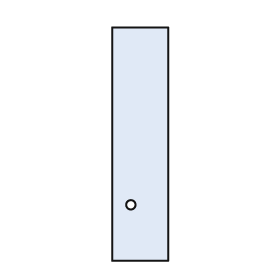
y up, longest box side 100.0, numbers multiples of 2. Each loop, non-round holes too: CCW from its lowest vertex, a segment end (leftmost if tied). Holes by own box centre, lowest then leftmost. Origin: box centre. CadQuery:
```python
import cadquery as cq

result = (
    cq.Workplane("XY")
    .moveTo(-12.0, -50.0)
    .lineTo(12.0, -50.0)
    .lineTo(12.0, 50.0)
    .lineTo(-12.0, 50.0)
    .close()
    .moveTo(-4.0, -26.0)
    .circle(2.0)
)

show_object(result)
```